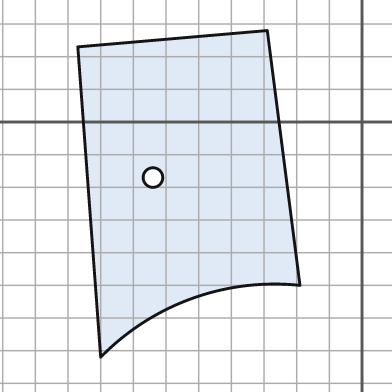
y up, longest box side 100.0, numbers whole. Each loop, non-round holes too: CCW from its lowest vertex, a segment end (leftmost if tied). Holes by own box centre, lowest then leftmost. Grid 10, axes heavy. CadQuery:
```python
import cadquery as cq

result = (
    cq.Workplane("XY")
    .moveTo(-80.0, -72.0)
    .threePointArc((-52.0, -54.0), (-19.0, -50.0))
    .lineTo(-29.0, 28.0)
    .lineTo(-87.0, 23.0)
    .close()
    .moveTo(-64.0, -17.0)
    .circle(3.0)
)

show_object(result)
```